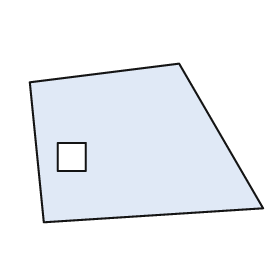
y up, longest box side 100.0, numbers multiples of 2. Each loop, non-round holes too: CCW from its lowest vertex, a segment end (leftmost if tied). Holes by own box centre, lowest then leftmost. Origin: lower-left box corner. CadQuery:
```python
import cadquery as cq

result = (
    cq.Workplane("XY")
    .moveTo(6.0, 0.0)
    .lineTo(100.0, 6.0)
    .lineTo(64.0, 68.0)
    .lineTo(0.0, 60.0)
    .close()
    .moveTo(12.0, 22.0)
    .lineTo(24.0, 22.0)
    .lineTo(24.0, 34.0)
    .lineTo(12.0, 34.0)
    .close()
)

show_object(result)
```